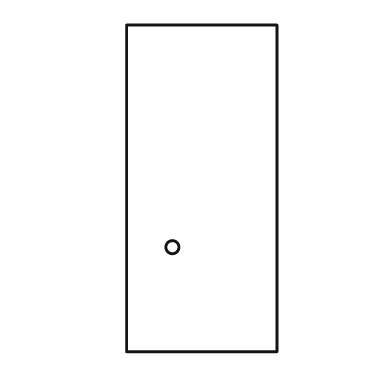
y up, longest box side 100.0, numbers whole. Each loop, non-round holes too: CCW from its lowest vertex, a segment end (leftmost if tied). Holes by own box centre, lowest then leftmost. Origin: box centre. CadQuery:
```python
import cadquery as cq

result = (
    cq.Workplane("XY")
    .moveTo(-23.0, -50.0)
    .lineTo(23.0, -50.0)
    .lineTo(23.0, 50.0)
    .lineTo(-23.0, 50.0)
    .close()
    .moveTo(-9.0, -18.0)
    .circle(2.0)
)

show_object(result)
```